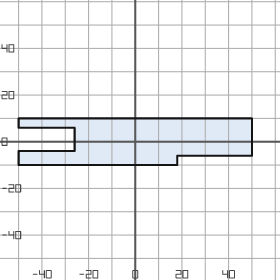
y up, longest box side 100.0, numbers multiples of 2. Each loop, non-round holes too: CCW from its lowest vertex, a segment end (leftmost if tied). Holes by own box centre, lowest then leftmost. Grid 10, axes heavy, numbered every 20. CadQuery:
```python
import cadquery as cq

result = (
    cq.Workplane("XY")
    .moveTo(-50.0, -10.0)
    .lineTo(18.0, -10.0)
    .lineTo(18.0, -6.0)
    .lineTo(50.0, -6.0)
    .lineTo(50.0, 10.0)
    .lineTo(-50.0, 10.0)
    .lineTo(-50.0, 6.0)
    .lineTo(-26.0, 6.0)
    .lineTo(-26.0, -4.0)
    .lineTo(-50.0, -4.0)
    .close()
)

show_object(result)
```